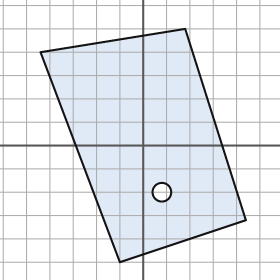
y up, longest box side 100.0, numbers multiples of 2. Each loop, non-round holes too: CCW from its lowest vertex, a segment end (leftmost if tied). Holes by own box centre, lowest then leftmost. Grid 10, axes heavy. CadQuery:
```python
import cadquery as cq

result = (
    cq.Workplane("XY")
    .moveTo(-10.0, -50.0)
    .lineTo(44.0, -32.0)
    .lineTo(18.0, 50.0)
    .lineTo(-44.0, 40.0)
    .close()
    .moveTo(8.0, -20.0)
    .circle(4.0)
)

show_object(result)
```